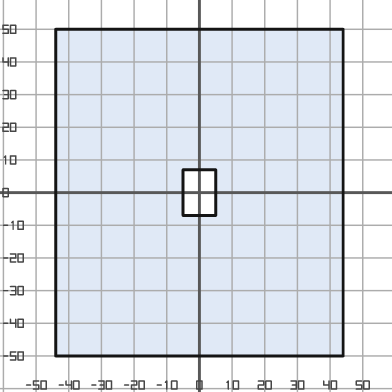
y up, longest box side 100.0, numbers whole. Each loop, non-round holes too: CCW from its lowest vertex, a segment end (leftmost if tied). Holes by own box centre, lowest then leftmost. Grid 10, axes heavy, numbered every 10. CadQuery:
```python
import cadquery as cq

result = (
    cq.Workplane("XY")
    .moveTo(-44.0, -50.0)
    .lineTo(44.0, -50.0)
    .lineTo(44.0, 50.0)
    .lineTo(-44.0, 50.0)
    .close()
    .moveTo(-5.0, -7.0)
    .lineTo(5.0, -7.0)
    .lineTo(5.0, 7.0)
    .lineTo(-5.0, 7.0)
    .close()
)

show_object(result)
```